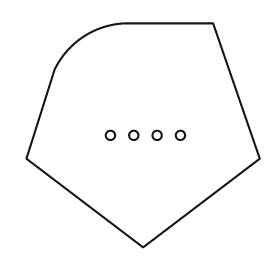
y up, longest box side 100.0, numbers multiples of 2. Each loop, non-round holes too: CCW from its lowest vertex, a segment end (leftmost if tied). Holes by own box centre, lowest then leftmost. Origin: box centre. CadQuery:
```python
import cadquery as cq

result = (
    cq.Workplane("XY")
    .moveTo(0.0, -48.0)
    .lineTo(50.0, -10.0)
    .lineTo(30.0, 48.0)
    .lineTo(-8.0, 48.0)
    .threePointArc((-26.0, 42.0), (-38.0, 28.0))
    .lineTo(-50.0, -10.0)
    .close()
    .moveTo(-14.0, 0.0)
    .circle(2.0)
    .moveTo(-4.0, 0.0)
    .circle(2.0)
    .moveTo(6.0, 0.0)
    .circle(2.0)
    .moveTo(16.0, 0.0)
    .circle(2.0)
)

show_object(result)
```